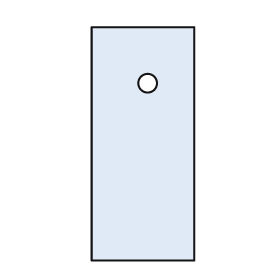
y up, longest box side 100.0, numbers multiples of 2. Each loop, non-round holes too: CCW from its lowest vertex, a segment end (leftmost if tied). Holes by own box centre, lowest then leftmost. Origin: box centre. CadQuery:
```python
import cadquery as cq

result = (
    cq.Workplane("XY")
    .moveTo(-22.0, -50.0)
    .lineTo(22.0, -50.0)
    .lineTo(22.0, 50.0)
    .lineTo(-22.0, 50.0)
    .close()
    .moveTo(2.0, 26.0)
    .circle(4.0)
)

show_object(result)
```